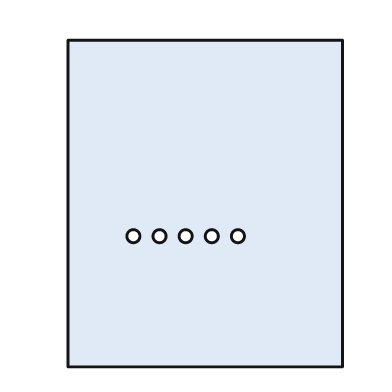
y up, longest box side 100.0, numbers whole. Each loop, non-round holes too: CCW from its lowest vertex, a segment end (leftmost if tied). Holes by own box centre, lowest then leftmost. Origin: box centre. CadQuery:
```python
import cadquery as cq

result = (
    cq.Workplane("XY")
    .moveTo(-42.0, -50.0)
    .lineTo(42.0, -50.0)
    .lineTo(42.0, 50.0)
    .lineTo(-42.0, 50.0)
    .close()
    .moveTo(-22.0, -10.0)
    .circle(2.0)
    .moveTo(-14.0, -10.0)
    .circle(2.0)
    .moveTo(-6.0, -10.0)
    .circle(2.0)
    .moveTo(2.0, -10.0)
    .circle(2.0)
    .moveTo(10.0, -10.0)
    .circle(2.0)
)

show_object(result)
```